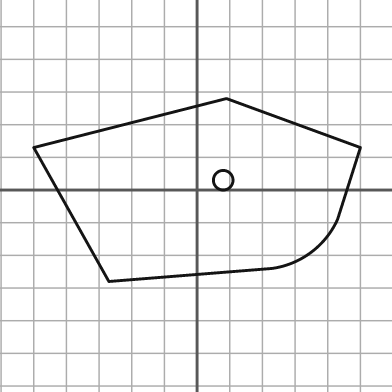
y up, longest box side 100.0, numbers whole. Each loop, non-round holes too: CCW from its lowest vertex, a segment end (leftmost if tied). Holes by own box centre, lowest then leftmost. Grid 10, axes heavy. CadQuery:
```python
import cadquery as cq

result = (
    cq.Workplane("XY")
    .moveTo(-27.0, -28.0)
    .lineTo(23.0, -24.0)
    .threePointArc((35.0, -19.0), (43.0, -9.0))
    .lineTo(50.0, 13.0)
    .lineTo(9.0, 28.0)
    .lineTo(-50.0, 13.0)
    .close()
    .moveTo(8.0, 3.0)
    .circle(3.0)
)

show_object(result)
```